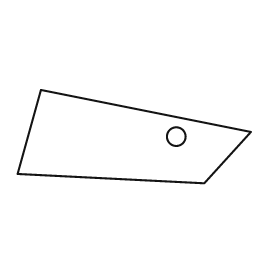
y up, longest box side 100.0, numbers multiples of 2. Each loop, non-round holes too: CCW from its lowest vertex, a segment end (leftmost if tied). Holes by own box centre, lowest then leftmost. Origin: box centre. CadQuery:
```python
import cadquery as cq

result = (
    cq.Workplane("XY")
    .moveTo(30.0, -20.0)
    .lineTo(50.0, 2.0)
    .lineTo(-40.0, 20.0)
    .lineTo(-50.0, -16.0)
    .close()
    .moveTo(18.0, 0.0)
    .circle(4.0)
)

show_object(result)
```